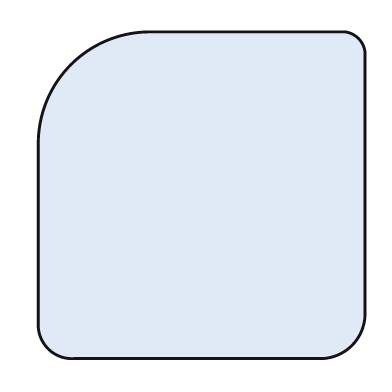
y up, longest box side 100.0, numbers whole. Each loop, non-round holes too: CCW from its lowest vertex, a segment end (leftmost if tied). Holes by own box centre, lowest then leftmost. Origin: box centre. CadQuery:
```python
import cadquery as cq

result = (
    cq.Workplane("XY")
    .moveTo(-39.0, -50.0)
    .lineTo(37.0, -50.0)
    .threePointArc((46.0, -46.0), (50.0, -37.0))
    .lineTo(50.0, 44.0)
    .threePointArc((48.0, 48.0), (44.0, 50.0))
    .lineTo(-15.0, 50.0)
    .threePointArc((-40.0, 40.0), (-50.0, 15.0))
    .lineTo(-50.0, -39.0)
    .threePointArc((-47.0, -47.0), (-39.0, -50.0))
    .close()
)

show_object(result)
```